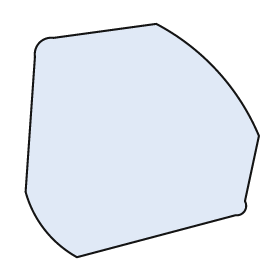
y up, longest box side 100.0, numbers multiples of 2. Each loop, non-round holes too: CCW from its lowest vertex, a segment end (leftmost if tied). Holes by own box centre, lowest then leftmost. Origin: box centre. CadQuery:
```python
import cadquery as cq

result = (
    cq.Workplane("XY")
    .moveTo(-28.0, -50.0)
    .lineTo(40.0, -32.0)
    .threePointArc((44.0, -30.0), (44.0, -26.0))
    .lineTo(50.0, 2.0)
    .threePointArc((32.0, 30.0), (6.0, 50.0))
    .lineTo(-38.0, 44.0)
    .threePointArc((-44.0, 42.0), (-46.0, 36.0))
    .lineTo(-50.0, -22.0)
    .threePointArc((-42.0, -38.0), (-28.0, -50.0))
    .close()
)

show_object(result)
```